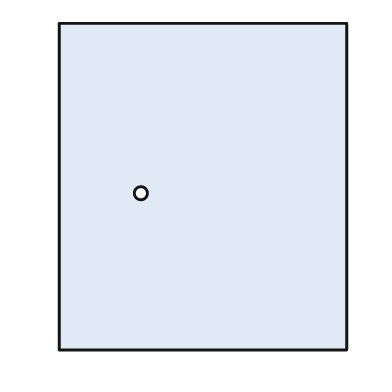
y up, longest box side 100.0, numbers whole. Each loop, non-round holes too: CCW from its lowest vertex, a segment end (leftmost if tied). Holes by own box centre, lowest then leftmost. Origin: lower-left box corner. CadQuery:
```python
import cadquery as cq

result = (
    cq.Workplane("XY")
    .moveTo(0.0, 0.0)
    .lineTo(88.0, 0.0)
    .lineTo(88.0, 100.0)
    .lineTo(0.0, 100.0)
    .close()
    .moveTo(25.0, 48.0)
    .circle(2.0)
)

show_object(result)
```